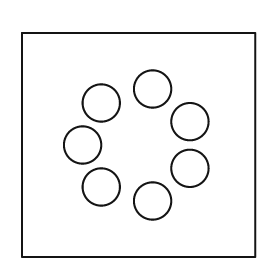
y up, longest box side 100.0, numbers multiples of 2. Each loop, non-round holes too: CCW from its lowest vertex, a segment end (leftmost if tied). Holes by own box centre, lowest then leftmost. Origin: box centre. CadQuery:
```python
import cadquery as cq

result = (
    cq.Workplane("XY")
    .moveTo(-50.0, -48.0)
    .lineTo(50.0, -48.0)
    .lineTo(50.0, 48.0)
    .lineTo(-50.0, 48.0)
    .close()
    .moveTo(6.0, -24.0)
    .circle(8.0)
    .moveTo(-16.0, -18.0)
    .circle(8.0)
    .moveTo(22.0, -10.0)
    .circle(8.0)
    .moveTo(-24.0, 0.0)
    .circle(8.0)
    .moveTo(22.0, 10.0)
    .circle(8.0)
    .moveTo(-16.0, 18.0)
    .circle(8.0)
    .moveTo(6.0, 24.0)
    .circle(8.0)
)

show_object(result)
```